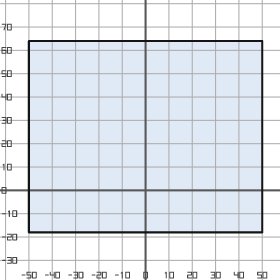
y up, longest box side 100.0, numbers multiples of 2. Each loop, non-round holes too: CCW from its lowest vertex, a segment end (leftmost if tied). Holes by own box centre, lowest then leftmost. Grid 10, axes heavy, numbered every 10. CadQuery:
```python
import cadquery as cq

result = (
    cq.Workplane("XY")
    .moveTo(-50.0, -18.0)
    .lineTo(50.0, -18.0)
    .lineTo(50.0, 64.0)
    .lineTo(-50.0, 64.0)
    .close()
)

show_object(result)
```